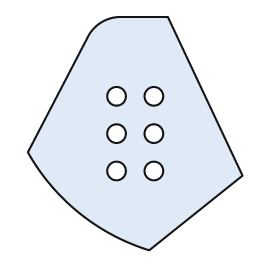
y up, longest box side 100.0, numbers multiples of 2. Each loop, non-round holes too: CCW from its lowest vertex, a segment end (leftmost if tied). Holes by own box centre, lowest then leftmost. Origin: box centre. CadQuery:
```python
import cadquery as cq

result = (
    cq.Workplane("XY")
    .moveTo(6.0, -50.0)
    .lineTo(46.0, -18.0)
    .lineTo(14.0, 50.0)
    .lineTo(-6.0, 50.0)
    .threePointArc((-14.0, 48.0), (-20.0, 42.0))
    .lineTo(-46.0, -8.0)
    .threePointArc((-24.0, -34.0), (6.0, -50.0))
    .close()
    .moveTo(-8.0, -16.0)
    .circle(4.0)
    .moveTo(8.0, -16.0)
    .circle(4.0)
    .moveTo(-8.0, 0.0)
    .circle(4.0)
    .moveTo(8.0, 0.0)
    .circle(4.0)
    .moveTo(-8.0, 16.0)
    .circle(4.0)
    .moveTo(8.0, 16.0)
    .circle(4.0)
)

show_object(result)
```